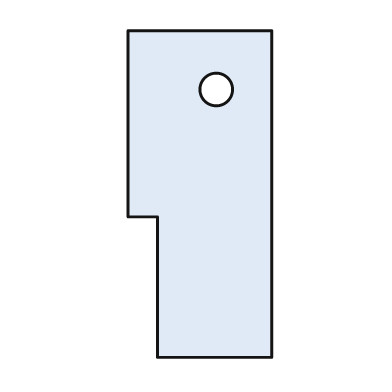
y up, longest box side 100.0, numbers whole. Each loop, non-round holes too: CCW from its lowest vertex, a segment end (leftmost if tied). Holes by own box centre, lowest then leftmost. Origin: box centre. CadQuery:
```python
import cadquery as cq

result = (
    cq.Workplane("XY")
    .moveTo(-13.0, -50.0)
    .lineTo(22.0, -50.0)
    .lineTo(22.0, 50.0)
    .lineTo(-22.0, 50.0)
    .lineTo(-22.0, -7.0)
    .lineTo(-13.0, -7.0)
    .close()
    .moveTo(5.0, 32.0)
    .circle(5.0)
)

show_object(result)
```